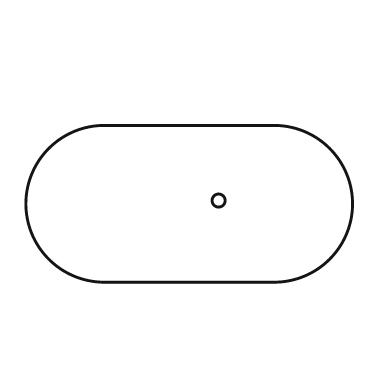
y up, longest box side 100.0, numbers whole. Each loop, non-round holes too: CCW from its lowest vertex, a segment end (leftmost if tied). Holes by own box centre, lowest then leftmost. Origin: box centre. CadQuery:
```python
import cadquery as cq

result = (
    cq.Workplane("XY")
    .moveTo(-26.0, -24.0)
    .lineTo(26.0, -24.0)
    .threePointArc((50.0, 0.0), (26.0, 24.0))
    .lineTo(-26.0, 24.0)
    .threePointArc((-50.0, 0.0), (-26.0, -24.0))
    .close()
    .moveTo(9.0, 1.0)
    .circle(2.0)
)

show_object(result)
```